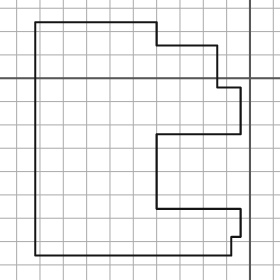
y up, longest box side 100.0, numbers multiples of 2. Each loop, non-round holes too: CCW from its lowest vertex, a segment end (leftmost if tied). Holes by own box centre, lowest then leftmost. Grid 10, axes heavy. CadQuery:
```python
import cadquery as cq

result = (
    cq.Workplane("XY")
    .moveTo(-92.0, -76.0)
    .lineTo(-8.0, -76.0)
    .lineTo(-8.0, -68.0)
    .lineTo(-4.0, -68.0)
    .lineTo(-4.0, -56.0)
    .lineTo(-40.0, -56.0)
    .lineTo(-40.0, -24.0)
    .lineTo(-4.0, -24.0)
    .lineTo(-4.0, -4.0)
    .lineTo(-14.0, -4.0)
    .lineTo(-14.0, 14.0)
    .lineTo(-40.0, 14.0)
    .lineTo(-40.0, 24.0)
    .lineTo(-92.0, 24.0)
    .close()
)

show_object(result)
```